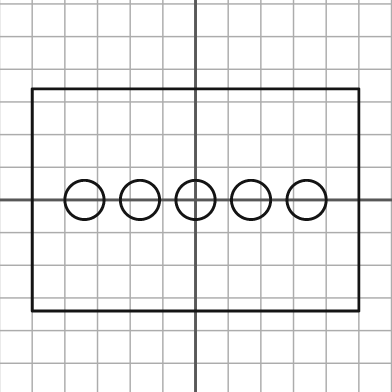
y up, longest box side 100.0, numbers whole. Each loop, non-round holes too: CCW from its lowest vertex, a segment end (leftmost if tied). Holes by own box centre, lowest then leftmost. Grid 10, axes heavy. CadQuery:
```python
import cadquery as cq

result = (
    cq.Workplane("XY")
    .moveTo(-50.0, -34.0)
    .lineTo(50.0, -34.0)
    .lineTo(50.0, 34.0)
    .lineTo(-50.0, 34.0)
    .close()
    .moveTo(-34.0, 0.0)
    .circle(6.0)
    .moveTo(-17.0, 0.0)
    .circle(6.0)
    .moveTo(0.0, 0.0)
    .circle(6.0)
    .moveTo(17.0, 0.0)
    .circle(6.0)
    .moveTo(34.0, 0.0)
    .circle(6.0)
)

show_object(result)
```